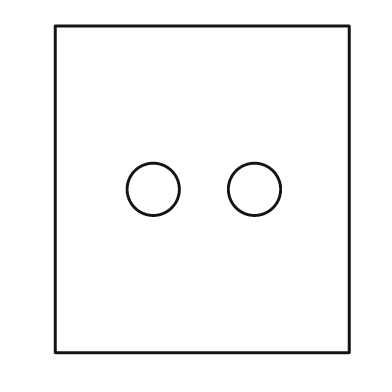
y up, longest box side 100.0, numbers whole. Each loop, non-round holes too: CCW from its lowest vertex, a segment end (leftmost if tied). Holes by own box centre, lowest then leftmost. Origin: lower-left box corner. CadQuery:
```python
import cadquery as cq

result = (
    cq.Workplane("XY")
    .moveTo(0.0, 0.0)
    .lineTo(90.0, 0.0)
    .lineTo(90.0, 100.0)
    .lineTo(0.0, 100.0)
    .close()
    .moveTo(30.0, 50.0)
    .circle(8.0)
    .moveTo(61.0, 50.0)
    .circle(8.0)
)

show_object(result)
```